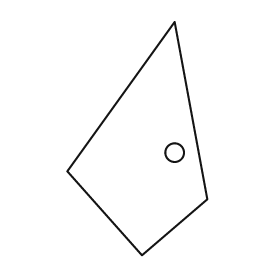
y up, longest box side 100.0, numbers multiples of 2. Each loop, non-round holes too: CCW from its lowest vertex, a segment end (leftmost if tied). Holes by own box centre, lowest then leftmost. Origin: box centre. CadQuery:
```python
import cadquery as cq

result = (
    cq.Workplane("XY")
    .moveTo(2.0, -50.0)
    .lineTo(30.0, -26.0)
    .lineTo(16.0, 50.0)
    .lineTo(-30.0, -14.0)
    .close()
    .moveTo(16.0, -6.0)
    .circle(4.0)
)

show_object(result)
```